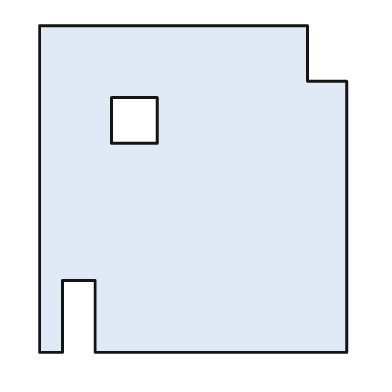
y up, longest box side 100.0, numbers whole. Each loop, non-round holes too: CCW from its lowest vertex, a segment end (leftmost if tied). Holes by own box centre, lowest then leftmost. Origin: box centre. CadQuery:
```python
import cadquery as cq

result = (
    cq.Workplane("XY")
    .moveTo(-47.0, -50.0)
    .lineTo(-40.0, -50.0)
    .lineTo(-40.0, -28.0)
    .lineTo(-30.0, -28.0)
    .lineTo(-30.0, -50.0)
    .lineTo(47.0, -50.0)
    .lineTo(47.0, 33.0)
    .lineTo(35.0, 33.0)
    .lineTo(35.0, 50.0)
    .lineTo(-47.0, 50.0)
    .close()
    .moveTo(-25.0, 14.0)
    .lineTo(-11.0, 14.0)
    .lineTo(-11.0, 28.0)
    .lineTo(-25.0, 28.0)
    .close()
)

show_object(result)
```